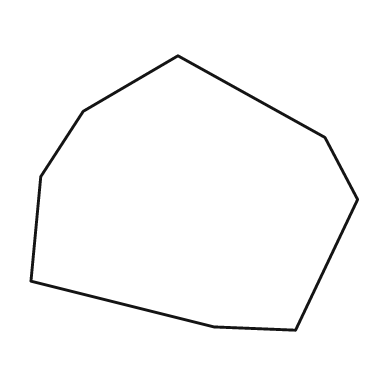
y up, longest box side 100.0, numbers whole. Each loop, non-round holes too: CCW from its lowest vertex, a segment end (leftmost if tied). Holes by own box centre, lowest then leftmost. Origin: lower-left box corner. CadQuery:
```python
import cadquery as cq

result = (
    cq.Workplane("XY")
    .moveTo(81.0, 0.0)
    .lineTo(100.0, 40.0)
    .lineTo(90.0, 59.0)
    .lineTo(45.0, 84.0)
    .lineTo(16.0, 67.0)
    .lineTo(3.0, 47.0)
    .lineTo(0.0, 15.0)
    .lineTo(56.0, 1.0)
    .close()
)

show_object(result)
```